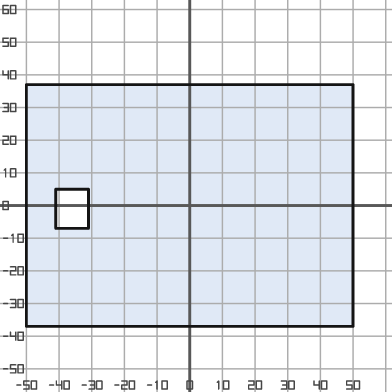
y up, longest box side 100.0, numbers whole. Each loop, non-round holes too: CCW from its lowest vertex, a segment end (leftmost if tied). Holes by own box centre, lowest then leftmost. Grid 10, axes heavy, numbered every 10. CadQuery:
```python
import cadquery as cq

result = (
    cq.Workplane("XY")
    .moveTo(-50.0, -37.0)
    .lineTo(50.0, -37.0)
    .lineTo(50.0, 37.0)
    .lineTo(-50.0, 37.0)
    .close()
    .moveTo(-41.0, -7.0)
    .lineTo(-31.0, -7.0)
    .lineTo(-31.0, 5.0)
    .lineTo(-41.0, 5.0)
    .close()
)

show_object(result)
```